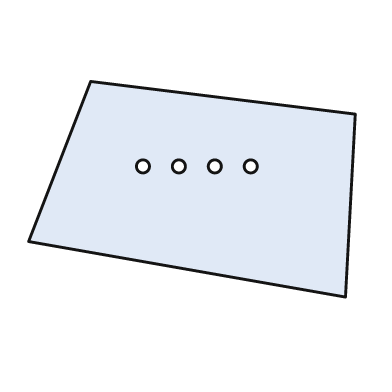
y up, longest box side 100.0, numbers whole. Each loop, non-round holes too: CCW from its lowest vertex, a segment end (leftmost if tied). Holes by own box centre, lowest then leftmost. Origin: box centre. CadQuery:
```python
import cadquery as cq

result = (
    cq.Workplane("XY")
    .moveTo(47.0, -33.0)
    .lineTo(50.0, 23.0)
    .lineTo(-31.0, 33.0)
    .lineTo(-50.0, -16.0)
    .close()
    .moveTo(-15.0, 7.0)
    .circle(2.0)
    .moveTo(-4.0, 7.0)
    .circle(2.0)
    .moveTo(7.0, 7.0)
    .circle(2.0)
    .moveTo(18.0, 7.0)
    .circle(2.0)
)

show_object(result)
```